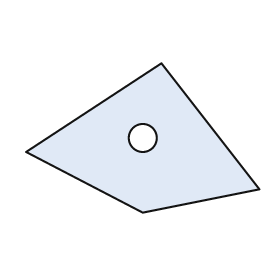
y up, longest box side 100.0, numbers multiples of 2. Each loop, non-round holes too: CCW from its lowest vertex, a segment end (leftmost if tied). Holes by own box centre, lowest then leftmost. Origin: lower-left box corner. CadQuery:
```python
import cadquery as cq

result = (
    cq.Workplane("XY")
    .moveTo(50.0, 0.0)
    .lineTo(100.0, 10.0)
    .lineTo(58.0, 64.0)
    .lineTo(0.0, 26.0)
    .close()
    .moveTo(50.0, 32.0)
    .circle(6.0)
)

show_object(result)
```